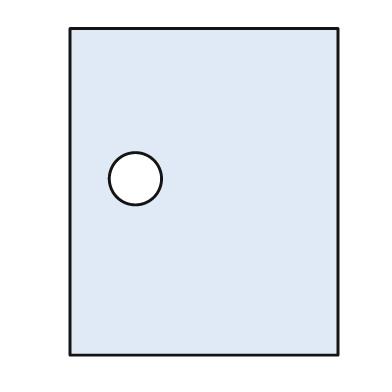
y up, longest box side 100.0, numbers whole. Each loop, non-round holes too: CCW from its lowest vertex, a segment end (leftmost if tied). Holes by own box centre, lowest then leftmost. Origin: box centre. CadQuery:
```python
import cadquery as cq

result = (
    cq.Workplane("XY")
    .moveTo(-41.0, -50.0)
    .lineTo(41.0, -50.0)
    .lineTo(41.0, 50.0)
    .lineTo(-41.0, 50.0)
    .close()
    .moveTo(-21.0, 4.0)
    .circle(8.0)
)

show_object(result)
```